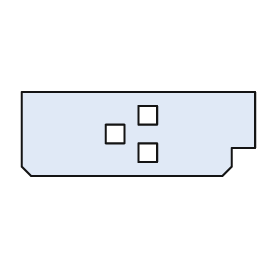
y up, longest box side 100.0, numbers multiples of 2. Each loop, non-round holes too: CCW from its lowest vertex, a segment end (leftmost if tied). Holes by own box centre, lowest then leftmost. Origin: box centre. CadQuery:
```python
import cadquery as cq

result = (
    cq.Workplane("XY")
    .moveTo(-46.0, -18.0)
    .lineTo(36.0, -18.0)
    .lineTo(40.0, -14.0)
    .lineTo(40.0, -6.0)
    .lineTo(50.0, -6.0)
    .lineTo(50.0, 18.0)
    .lineTo(-50.0, 18.0)
    .lineTo(-50.0, -14.0)
    .close()
    .moveTo(0.0, -12.0)
    .lineTo(8.0, -12.0)
    .lineTo(8.0, -4.0)
    .lineTo(0.0, -4.0)
    .close()
    .moveTo(-14.0, -4.0)
    .lineTo(-6.0, -4.0)
    .lineTo(-6.0, 4.0)
    .lineTo(-14.0, 4.0)
    .close()
    .moveTo(0.0, 4.0)
    .lineTo(8.0, 4.0)
    .lineTo(8.0, 12.0)
    .lineTo(0.0, 12.0)
    .close()
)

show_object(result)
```